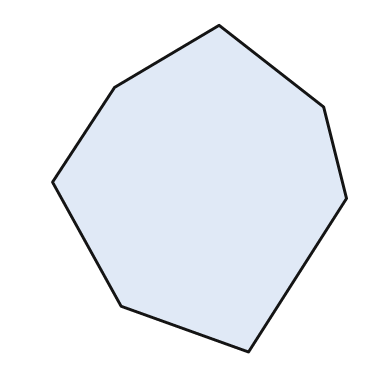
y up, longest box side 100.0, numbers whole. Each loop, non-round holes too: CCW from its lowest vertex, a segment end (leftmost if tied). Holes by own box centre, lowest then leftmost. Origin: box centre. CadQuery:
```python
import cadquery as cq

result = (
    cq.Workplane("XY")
    .moveTo(15.0, -50.0)
    .lineTo(45.0, -3.0)
    .lineTo(38.0, 25.0)
    .lineTo(6.0, 50.0)
    .lineTo(-26.0, 31.0)
    .lineTo(-45.0, 2.0)
    .lineTo(-24.0, -36.0)
    .close()
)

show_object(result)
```